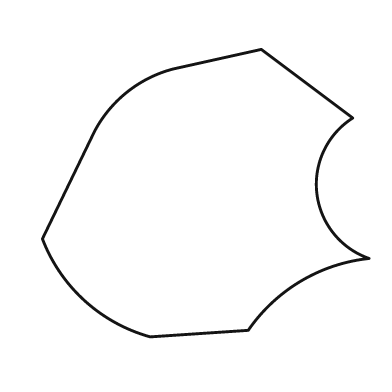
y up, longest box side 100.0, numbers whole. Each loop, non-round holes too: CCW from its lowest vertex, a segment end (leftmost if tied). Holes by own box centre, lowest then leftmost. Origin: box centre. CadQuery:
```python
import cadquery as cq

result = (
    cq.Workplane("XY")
    .moveTo(-17.0, -44.0)
    .lineTo(13.0, -42.0)
    .threePointArc((29.0, -27.0), (50.0, -20.0))
    .threePointArc((34.0, 0.0), (45.0, 23.0))
    .lineTo(17.0, 44.0)
    .lineTo(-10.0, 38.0)
    .threePointArc((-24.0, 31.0), (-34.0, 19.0))
    .lineTo(-50.0, -14.0)
    .threePointArc((-37.0, -33.0), (-17.0, -44.0))
    .close()
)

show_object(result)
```